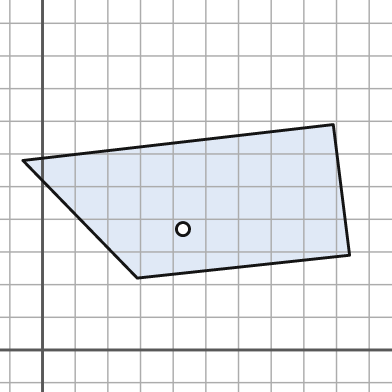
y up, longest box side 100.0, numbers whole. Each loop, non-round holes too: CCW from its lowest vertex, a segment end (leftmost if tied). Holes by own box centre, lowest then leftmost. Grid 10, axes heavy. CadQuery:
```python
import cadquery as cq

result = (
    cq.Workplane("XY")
    .moveTo(29.0, 22.0)
    .lineTo(94.0, 29.0)
    .lineTo(89.0, 69.0)
    .lineTo(-6.0, 58.0)
    .close()
    .moveTo(43.0, 37.0)
    .circle(2.0)
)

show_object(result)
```